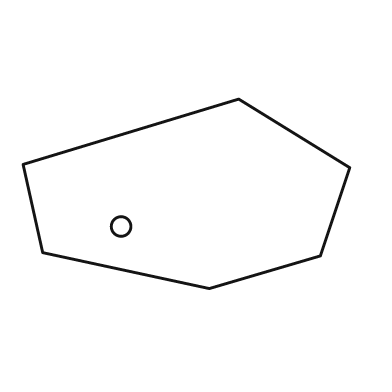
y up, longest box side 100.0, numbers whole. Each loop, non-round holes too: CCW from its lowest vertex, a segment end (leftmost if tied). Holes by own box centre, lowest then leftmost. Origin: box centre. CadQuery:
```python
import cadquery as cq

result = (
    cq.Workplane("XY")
    .moveTo(7.0, -29.0)
    .lineTo(41.0, -19.0)
    .lineTo(50.0, 8.0)
    .lineTo(16.0, 29.0)
    .lineTo(-50.0, 9.0)
    .lineTo(-44.0, -18.0)
    .close()
    .moveTo(-20.0, -10.0)
    .circle(3.0)
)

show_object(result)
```